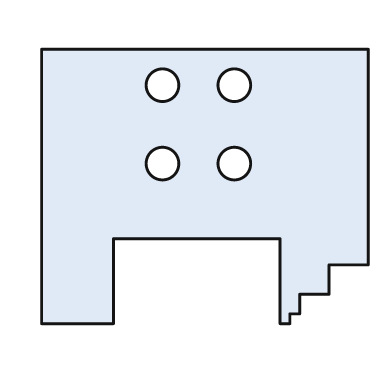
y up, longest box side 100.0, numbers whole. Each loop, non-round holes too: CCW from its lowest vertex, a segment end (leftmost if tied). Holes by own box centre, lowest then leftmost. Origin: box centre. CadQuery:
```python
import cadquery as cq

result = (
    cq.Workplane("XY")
    .moveTo(-50.0, -42.0)
    .lineTo(-28.0, -42.0)
    .lineTo(-28.0, -16.0)
    .lineTo(23.0, -16.0)
    .lineTo(23.0, -42.0)
    .lineTo(26.0, -42.0)
    .lineTo(26.0, -39.0)
    .lineTo(29.0, -39.0)
    .lineTo(29.0, -33.0)
    .lineTo(38.0, -33.0)
    .lineTo(38.0, -24.0)
    .lineTo(50.0, -24.0)
    .lineTo(50.0, 42.0)
    .lineTo(-50.0, 42.0)
    .close()
    .moveTo(-13.0, 7.0)
    .circle(5.0)
    .moveTo(9.0, 7.0)
    .circle(5.0)
    .moveTo(-13.0, 31.0)
    .circle(5.0)
    .moveTo(9.0, 31.0)
    .circle(5.0)
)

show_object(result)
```